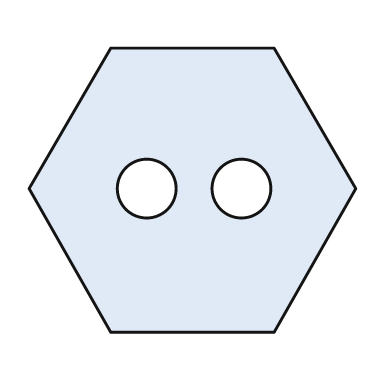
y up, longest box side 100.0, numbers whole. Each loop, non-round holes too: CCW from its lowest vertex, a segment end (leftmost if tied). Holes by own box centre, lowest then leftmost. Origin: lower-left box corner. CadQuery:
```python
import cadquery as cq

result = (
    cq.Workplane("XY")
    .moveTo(25.0, 0.0)
    .lineTo(75.0, 0.0)
    .lineTo(100.0, 44.0)
    .lineTo(75.0, 87.0)
    .lineTo(25.0, 87.0)
    .lineTo(0.0, 44.0)
    .close()
    .moveTo(36.0, 44.0)
    .circle(9.0)
    .moveTo(65.0, 44.0)
    .circle(9.0)
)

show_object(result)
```